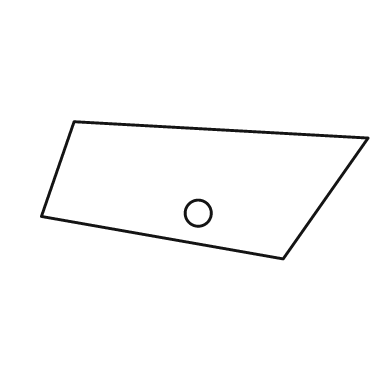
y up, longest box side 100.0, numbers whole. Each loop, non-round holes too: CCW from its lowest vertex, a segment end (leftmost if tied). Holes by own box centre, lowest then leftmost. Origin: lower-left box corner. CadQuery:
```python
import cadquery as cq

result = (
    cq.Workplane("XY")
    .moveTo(74.0, 0.0)
    .lineTo(100.0, 37.0)
    .lineTo(10.0, 42.0)
    .lineTo(0.0, 13.0)
    .close()
    .moveTo(48.0, 14.0)
    .circle(4.0)
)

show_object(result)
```